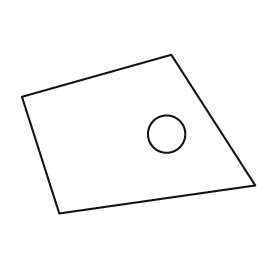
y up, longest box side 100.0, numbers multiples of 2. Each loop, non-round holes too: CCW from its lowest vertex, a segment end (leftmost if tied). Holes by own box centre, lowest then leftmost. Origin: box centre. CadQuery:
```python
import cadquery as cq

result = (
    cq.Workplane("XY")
    .moveTo(-34.0, -34.0)
    .lineTo(50.0, -22.0)
    .lineTo(14.0, 34.0)
    .lineTo(-50.0, 16.0)
    .close()
    .moveTo(12.0, 0.0)
    .circle(8.0)
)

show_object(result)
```